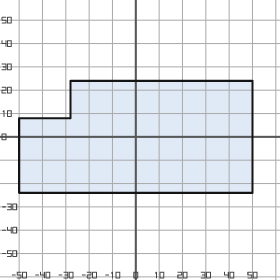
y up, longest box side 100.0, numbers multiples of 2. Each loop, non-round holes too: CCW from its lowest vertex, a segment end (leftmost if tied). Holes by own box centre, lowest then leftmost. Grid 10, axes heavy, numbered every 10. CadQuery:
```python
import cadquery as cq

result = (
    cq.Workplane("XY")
    .moveTo(-50.0, -24.0)
    .lineTo(50.0, -24.0)
    .lineTo(50.0, 24.0)
    .lineTo(-28.0, 24.0)
    .lineTo(-28.0, 8.0)
    .lineTo(-50.0, 8.0)
    .close()
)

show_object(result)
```